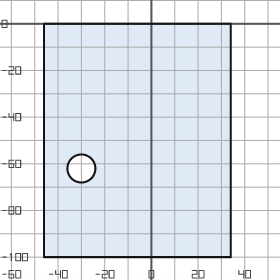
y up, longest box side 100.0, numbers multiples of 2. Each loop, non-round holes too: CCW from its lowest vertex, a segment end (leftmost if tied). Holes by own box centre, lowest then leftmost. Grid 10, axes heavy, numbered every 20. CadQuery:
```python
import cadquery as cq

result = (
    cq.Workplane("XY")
    .moveTo(-46.0, -100.0)
    .lineTo(34.0, -100.0)
    .lineTo(34.0, 0.0)
    .lineTo(-46.0, 0.0)
    .close()
    .moveTo(-30.0, -62.0)
    .circle(6.0)
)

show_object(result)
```